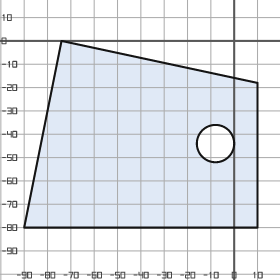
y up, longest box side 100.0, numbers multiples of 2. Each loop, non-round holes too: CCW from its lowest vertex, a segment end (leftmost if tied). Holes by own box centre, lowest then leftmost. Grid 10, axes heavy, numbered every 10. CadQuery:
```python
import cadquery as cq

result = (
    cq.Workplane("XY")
    .moveTo(-90.0, -80.0)
    .lineTo(10.0, -80.0)
    .lineTo(10.0, -18.0)
    .lineTo(-74.0, 0.0)
    .close()
    .moveTo(-8.0, -44.0)
    .circle(8.0)
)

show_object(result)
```